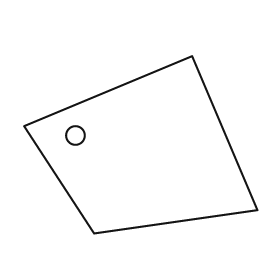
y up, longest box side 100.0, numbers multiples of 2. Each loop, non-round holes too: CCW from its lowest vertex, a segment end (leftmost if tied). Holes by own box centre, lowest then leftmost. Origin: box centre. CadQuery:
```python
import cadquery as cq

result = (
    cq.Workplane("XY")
    .moveTo(-20.0, -38.0)
    .lineTo(50.0, -28.0)
    .lineTo(22.0, 38.0)
    .lineTo(-50.0, 8.0)
    .close()
    .moveTo(-28.0, 4.0)
    .circle(4.0)
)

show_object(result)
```